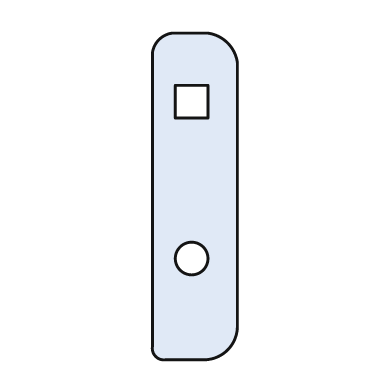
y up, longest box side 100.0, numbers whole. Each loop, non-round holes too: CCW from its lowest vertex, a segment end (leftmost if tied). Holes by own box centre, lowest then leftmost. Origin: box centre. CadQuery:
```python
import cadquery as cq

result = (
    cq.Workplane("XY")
    .moveTo(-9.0, -50.0)
    .lineTo(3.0, -50.0)
    .threePointArc((10.0, -47.0), (13.0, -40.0))
    .lineTo(13.0, 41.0)
    .threePointArc((10.0, 47.0), (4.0, 50.0))
    .lineTo(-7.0, 50.0)
    .threePointArc((-11.0, 48.0), (-13.0, 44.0))
    .lineTo(-13.0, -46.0)
    .threePointArc((-12.0, -49.0), (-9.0, -50.0))
    .close()
    .moveTo(-1.0, -19.0)
    .circle(5.0)
    .moveTo(-6.0, 24.0)
    .lineTo(4.0, 24.0)
    .lineTo(4.0, 34.0)
    .lineTo(-6.0, 34.0)
    .close()
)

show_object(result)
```